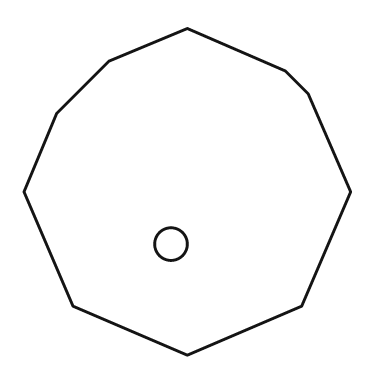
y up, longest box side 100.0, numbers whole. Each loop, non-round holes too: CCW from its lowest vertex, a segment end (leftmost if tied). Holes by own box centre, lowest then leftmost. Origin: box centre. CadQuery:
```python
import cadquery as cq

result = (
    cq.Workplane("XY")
    .moveTo(0.0, -50.0)
    .lineTo(35.0, -35.0)
    .lineTo(50.0, 0.0)
    .lineTo(37.0, 30.0)
    .lineTo(30.0, 37.0)
    .lineTo(0.0, 50.0)
    .lineTo(-24.0, 40.0)
    .lineTo(-40.0, 24.0)
    .lineTo(-50.0, 0.0)
    .lineTo(-35.0, -35.0)
    .close()
    .moveTo(-5.0, -16.0)
    .circle(5.0)
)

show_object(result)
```